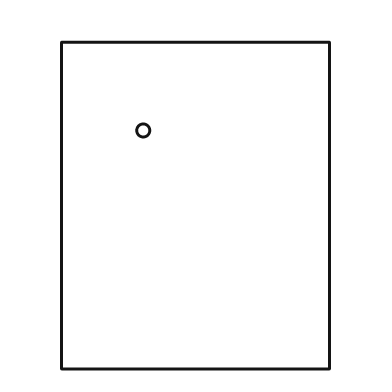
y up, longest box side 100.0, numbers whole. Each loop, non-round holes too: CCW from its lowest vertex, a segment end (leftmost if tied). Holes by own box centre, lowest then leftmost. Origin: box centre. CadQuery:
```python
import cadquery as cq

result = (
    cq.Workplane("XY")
    .moveTo(-41.0, -50.0)
    .lineTo(41.0, -50.0)
    .lineTo(41.0, 50.0)
    .lineTo(-41.0, 50.0)
    .close()
    .moveTo(-16.0, 23.0)
    .circle(2.0)
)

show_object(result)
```